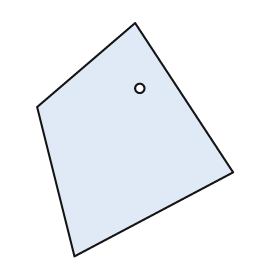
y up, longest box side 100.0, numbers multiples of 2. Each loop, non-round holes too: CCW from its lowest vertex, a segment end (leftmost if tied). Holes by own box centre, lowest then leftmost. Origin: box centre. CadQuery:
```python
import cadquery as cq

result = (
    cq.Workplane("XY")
    .moveTo(-26.0, -50.0)
    .lineTo(42.0, -14.0)
    .lineTo(0.0, 50.0)
    .lineTo(-42.0, 14.0)
    .close()
    .moveTo(2.0, 22.0)
    .circle(2.0)
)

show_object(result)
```